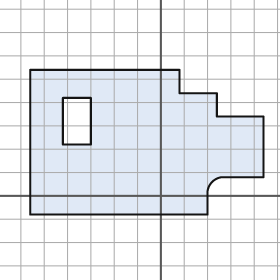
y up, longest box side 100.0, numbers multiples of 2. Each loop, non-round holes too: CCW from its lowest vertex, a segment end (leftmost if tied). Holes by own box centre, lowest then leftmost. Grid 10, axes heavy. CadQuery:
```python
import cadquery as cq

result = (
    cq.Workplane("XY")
    .moveTo(-56.0, -8.0)
    .lineTo(20.0, -8.0)
    .lineTo(20.0, 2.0)
    .threePointArc((22.0, 6.0), (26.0, 8.0))
    .lineTo(44.0, 8.0)
    .lineTo(44.0, 34.0)
    .lineTo(24.0, 34.0)
    .lineTo(24.0, 44.0)
    .lineTo(8.0, 44.0)
    .lineTo(8.0, 54.0)
    .lineTo(-56.0, 54.0)
    .close()
    .moveTo(-42.0, 22.0)
    .lineTo(-30.0, 22.0)
    .lineTo(-30.0, 42.0)
    .lineTo(-42.0, 42.0)
    .close()
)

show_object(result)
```